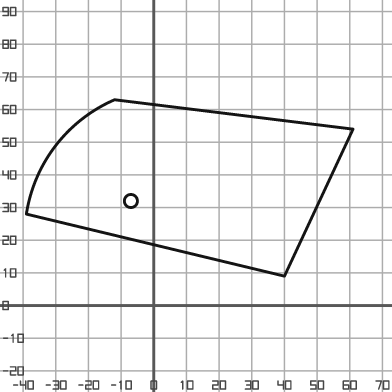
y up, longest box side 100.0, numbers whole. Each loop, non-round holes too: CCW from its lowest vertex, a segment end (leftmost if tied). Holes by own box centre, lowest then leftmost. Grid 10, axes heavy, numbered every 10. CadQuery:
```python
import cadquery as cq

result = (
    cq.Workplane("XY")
    .moveTo(40.0, 9.0)
    .lineTo(61.0, 54.0)
    .lineTo(-12.0, 63.0)
    .threePointArc((-30.0, 49.0), (-39.0, 28.0))
    .close()
    .moveTo(-7.0, 32.0)
    .circle(2.0)
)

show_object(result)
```